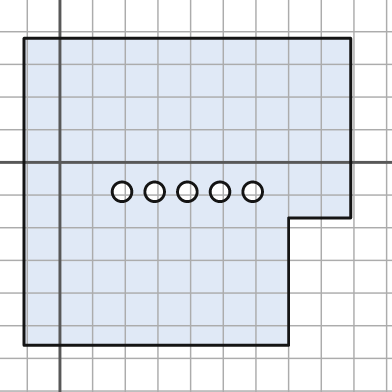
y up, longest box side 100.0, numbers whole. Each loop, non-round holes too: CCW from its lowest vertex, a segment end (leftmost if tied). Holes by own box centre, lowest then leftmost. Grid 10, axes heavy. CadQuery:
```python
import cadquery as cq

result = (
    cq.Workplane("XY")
    .moveTo(-11.0, -56.0)
    .lineTo(70.0, -56.0)
    .lineTo(70.0, -17.0)
    .lineTo(89.0, -17.0)
    .lineTo(89.0, 38.0)
    .lineTo(-11.0, 38.0)
    .close()
    .moveTo(19.0, -9.0)
    .circle(3.0)
    .moveTo(29.0, -9.0)
    .circle(3.0)
    .moveTo(39.0, -9.0)
    .circle(3.0)
    .moveTo(49.0, -9.0)
    .circle(3.0)
    .moveTo(59.0, -9.0)
    .circle(3.0)
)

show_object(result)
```